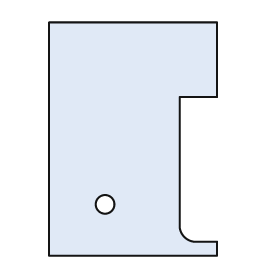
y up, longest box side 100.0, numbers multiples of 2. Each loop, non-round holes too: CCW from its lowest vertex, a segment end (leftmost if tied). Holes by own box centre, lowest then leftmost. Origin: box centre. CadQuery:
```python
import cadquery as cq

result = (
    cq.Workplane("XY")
    .moveTo(-36.0, -50.0)
    .lineTo(36.0, -50.0)
    .lineTo(36.0, -44.0)
    .lineTo(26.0, -44.0)
    .threePointArc((22.0, -42.0), (20.0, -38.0))
    .lineTo(20.0, 18.0)
    .lineTo(36.0, 18.0)
    .lineTo(36.0, 50.0)
    .lineTo(-36.0, 50.0)
    .close()
    .moveTo(-12.0, -28.0)
    .circle(4.0)
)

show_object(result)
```